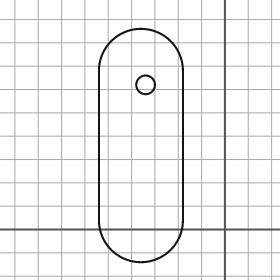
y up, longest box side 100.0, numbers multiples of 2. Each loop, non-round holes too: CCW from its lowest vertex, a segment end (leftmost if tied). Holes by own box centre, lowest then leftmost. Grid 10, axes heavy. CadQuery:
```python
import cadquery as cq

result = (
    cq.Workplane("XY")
    .moveTo(-54.0, 4.0)
    .threePointArc((-36.0, -14.0), (-18.0, 4.0))
    .lineTo(-18.0, 68.0)
    .threePointArc((-36.0, 86.0), (-54.0, 68.0))
    .close()
    .moveTo(-34.0, 62.0)
    .circle(4.0)
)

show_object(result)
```